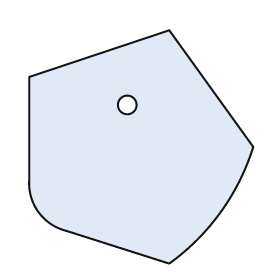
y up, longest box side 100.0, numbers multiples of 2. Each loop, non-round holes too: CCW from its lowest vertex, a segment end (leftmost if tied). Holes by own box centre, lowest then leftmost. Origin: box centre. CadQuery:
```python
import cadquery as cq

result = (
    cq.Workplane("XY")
    .moveTo(12.0, -50.0)
    .threePointArc((34.0, -28.0), (48.0, 0.0))
    .lineTo(12.0, 50.0)
    .lineTo(-48.0, 30.0)
    .lineTo(-48.0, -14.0)
    .threePointArc((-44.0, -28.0), (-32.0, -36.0))
    .close()
    .moveTo(-6.0, 18.0)
    .circle(4.0)
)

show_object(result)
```